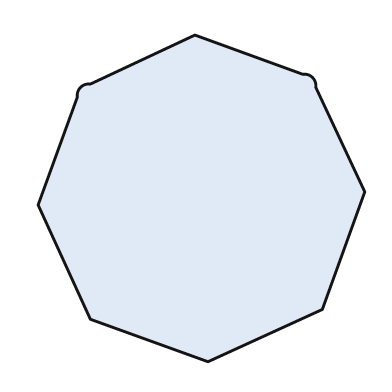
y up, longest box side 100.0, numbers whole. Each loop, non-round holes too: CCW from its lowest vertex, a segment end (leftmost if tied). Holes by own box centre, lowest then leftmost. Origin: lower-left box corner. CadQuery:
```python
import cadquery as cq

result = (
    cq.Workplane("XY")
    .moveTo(52.0, 0.0)
    .lineTo(87.0, 16.0)
    .lineTo(100.0, 52.0)
    .lineTo(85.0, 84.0)
    .threePointArc((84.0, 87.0), (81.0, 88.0))
    .lineTo(48.0, 100.0)
    .lineTo(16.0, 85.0)
    .threePointArc((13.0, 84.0), (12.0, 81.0))
    .lineTo(0.0, 48.0)
    .lineTo(16.0, 13.0)
    .close()
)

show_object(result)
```